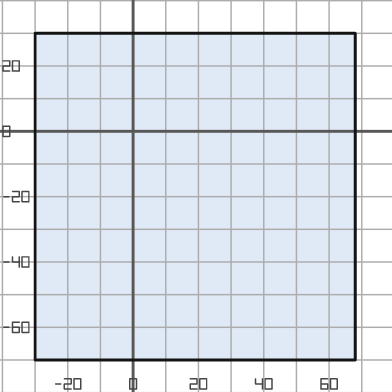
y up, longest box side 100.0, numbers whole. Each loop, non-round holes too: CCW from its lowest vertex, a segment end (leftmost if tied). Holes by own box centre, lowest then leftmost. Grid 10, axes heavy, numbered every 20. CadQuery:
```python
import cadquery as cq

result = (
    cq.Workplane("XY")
    .moveTo(-30.0, -70.0)
    .lineTo(68.0, -70.0)
    .lineTo(68.0, 30.0)
    .lineTo(-30.0, 30.0)
    .close()
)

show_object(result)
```